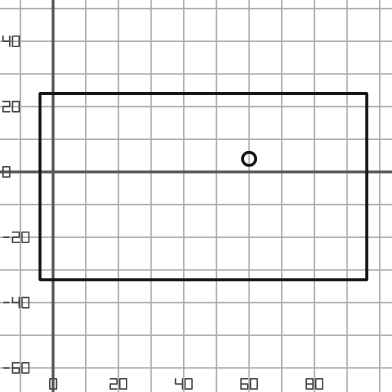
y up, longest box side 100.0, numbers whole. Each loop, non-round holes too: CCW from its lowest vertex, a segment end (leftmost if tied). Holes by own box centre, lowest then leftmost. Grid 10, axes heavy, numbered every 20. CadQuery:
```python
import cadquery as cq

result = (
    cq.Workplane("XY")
    .moveTo(-4.0, -33.0)
    .lineTo(96.0, -33.0)
    .lineTo(96.0, 24.0)
    .lineTo(-4.0, 24.0)
    .close()
    .moveTo(60.0, 4.0)
    .circle(2.0)
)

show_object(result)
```